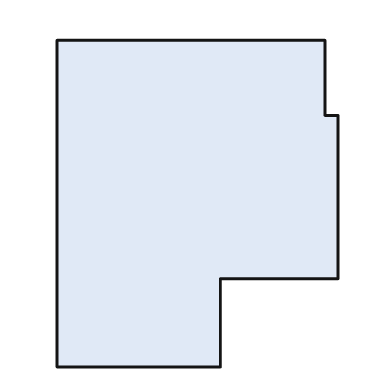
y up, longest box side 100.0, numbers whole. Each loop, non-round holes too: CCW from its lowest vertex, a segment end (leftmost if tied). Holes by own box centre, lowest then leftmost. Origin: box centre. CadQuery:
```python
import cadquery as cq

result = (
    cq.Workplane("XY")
    .moveTo(-43.0, -50.0)
    .lineTo(7.0, -50.0)
    .lineTo(7.0, -23.0)
    .lineTo(43.0, -23.0)
    .lineTo(43.0, 27.0)
    .lineTo(39.0, 27.0)
    .lineTo(39.0, 50.0)
    .lineTo(-43.0, 50.0)
    .close()
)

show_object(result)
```